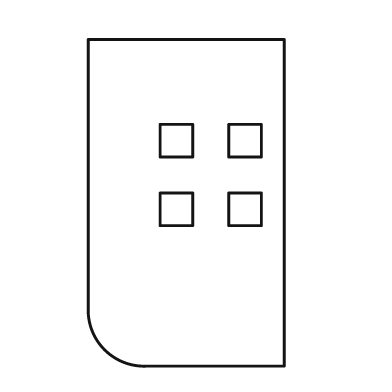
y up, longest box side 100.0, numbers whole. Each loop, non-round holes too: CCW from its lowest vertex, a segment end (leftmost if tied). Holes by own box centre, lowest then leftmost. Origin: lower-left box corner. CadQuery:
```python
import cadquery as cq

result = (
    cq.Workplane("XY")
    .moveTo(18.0, 0.0)
    .lineTo(60.0, 0.0)
    .lineTo(60.0, 100.0)
    .lineTo(0.0, 100.0)
    .lineTo(0.0, 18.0)
    .threePointArc((5.0, 5.0), (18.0, 0.0))
    .close()
    .moveTo(22.0, 43.0)
    .lineTo(32.0, 43.0)
    .lineTo(32.0, 53.0)
    .lineTo(22.0, 53.0)
    .close()
    .moveTo(43.0, 43.0)
    .lineTo(53.0, 43.0)
    .lineTo(53.0, 53.0)
    .lineTo(43.0, 53.0)
    .close()
    .moveTo(22.0, 64.0)
    .lineTo(32.0, 64.0)
    .lineTo(32.0, 74.0)
    .lineTo(22.0, 74.0)
    .close()
    .moveTo(43.0, 64.0)
    .lineTo(53.0, 64.0)
    .lineTo(53.0, 74.0)
    .lineTo(43.0, 74.0)
    .close()
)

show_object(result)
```